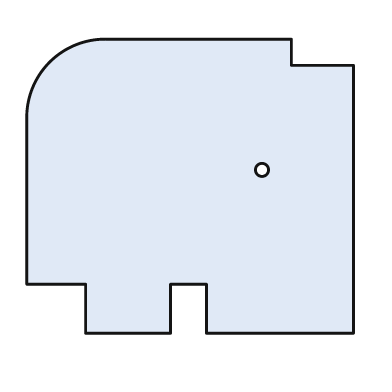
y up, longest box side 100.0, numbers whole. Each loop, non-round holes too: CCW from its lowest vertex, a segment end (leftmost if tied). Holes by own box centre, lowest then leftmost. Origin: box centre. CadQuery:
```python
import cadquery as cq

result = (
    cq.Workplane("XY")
    .moveTo(-32.0, -45.0)
    .lineTo(-6.0, -45.0)
    .lineTo(-6.0, -30.0)
    .lineTo(5.0, -30.0)
    .lineTo(5.0, -45.0)
    .lineTo(50.0, -45.0)
    .lineTo(50.0, 37.0)
    .lineTo(31.0, 37.0)
    .lineTo(31.0, 45.0)
    .lineTo(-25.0, 45.0)
    .threePointArc((-43.0, 38.0), (-50.0, 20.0))
    .lineTo(-50.0, -30.0)
    .lineTo(-32.0, -30.0)
    .close()
    .moveTo(22.0, 5.0)
    .circle(2.0)
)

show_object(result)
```